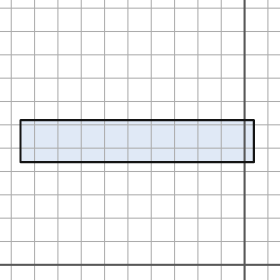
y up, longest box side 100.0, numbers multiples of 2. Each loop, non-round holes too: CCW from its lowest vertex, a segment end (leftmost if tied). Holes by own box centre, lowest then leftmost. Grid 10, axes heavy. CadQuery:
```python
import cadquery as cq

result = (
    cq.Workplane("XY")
    .moveTo(-96.0, 44.0)
    .lineTo(4.0, 44.0)
    .lineTo(4.0, 62.0)
    .lineTo(-96.0, 62.0)
    .close()
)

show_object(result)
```